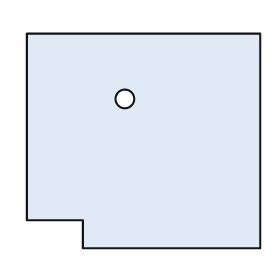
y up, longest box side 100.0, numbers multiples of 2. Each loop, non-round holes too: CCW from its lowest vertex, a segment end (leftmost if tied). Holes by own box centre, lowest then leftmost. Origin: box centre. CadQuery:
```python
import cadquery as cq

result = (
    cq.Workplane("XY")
    .moveTo(-26.0, -46.0)
    .lineTo(50.0, -46.0)
    .lineTo(50.0, 46.0)
    .lineTo(-50.0, 46.0)
    .lineTo(-50.0, -34.0)
    .lineTo(-26.0, -34.0)
    .close()
    .moveTo(-8.0, 18.0)
    .circle(4.0)
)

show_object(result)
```